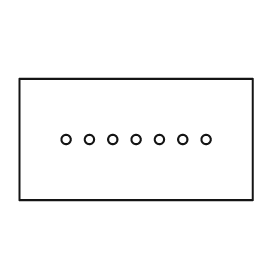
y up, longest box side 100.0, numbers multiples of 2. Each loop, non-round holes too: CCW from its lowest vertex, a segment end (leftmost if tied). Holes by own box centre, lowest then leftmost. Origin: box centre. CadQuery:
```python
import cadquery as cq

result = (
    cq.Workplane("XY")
    .moveTo(-50.0, -26.0)
    .lineTo(50.0, -26.0)
    .lineTo(50.0, 26.0)
    .lineTo(-50.0, 26.0)
    .close()
    .moveTo(-30.0, 0.0)
    .circle(2.0)
    .moveTo(-20.0, 0.0)
    .circle(2.0)
    .moveTo(-10.0, 0.0)
    .circle(2.0)
    .moveTo(0.0, 0.0)
    .circle(2.0)
    .moveTo(10.0, 0.0)
    .circle(2.0)
    .moveTo(20.0, 0.0)
    .circle(2.0)
    .moveTo(30.0, 0.0)
    .circle(2.0)
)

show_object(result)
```